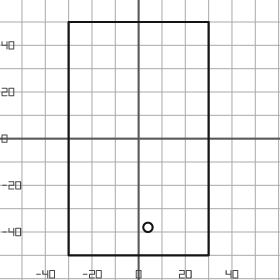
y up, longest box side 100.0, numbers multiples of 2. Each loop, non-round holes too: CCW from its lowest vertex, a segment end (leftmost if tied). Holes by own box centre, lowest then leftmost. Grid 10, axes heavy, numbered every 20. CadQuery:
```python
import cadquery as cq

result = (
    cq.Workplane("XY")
    .moveTo(-30.0, -50.0)
    .lineTo(30.0, -50.0)
    .lineTo(30.0, 50.0)
    .lineTo(-30.0, 50.0)
    .close()
    .moveTo(4.0, -38.0)
    .circle(2.0)
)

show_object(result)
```